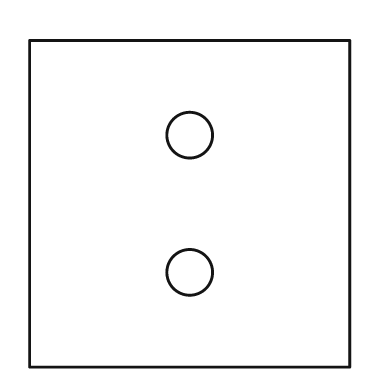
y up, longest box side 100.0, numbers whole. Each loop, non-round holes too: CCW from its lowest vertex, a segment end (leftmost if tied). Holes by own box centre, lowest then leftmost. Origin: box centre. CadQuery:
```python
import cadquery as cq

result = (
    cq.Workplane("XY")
    .moveTo(-49.0, -50.0)
    .lineTo(49.0, -50.0)
    .lineTo(49.0, 50.0)
    .lineTo(-49.0, 50.0)
    .close()
    .moveTo(0.0, -21.0)
    .circle(7.0)
    .moveTo(0.0, 21.0)
    .circle(7.0)
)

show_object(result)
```